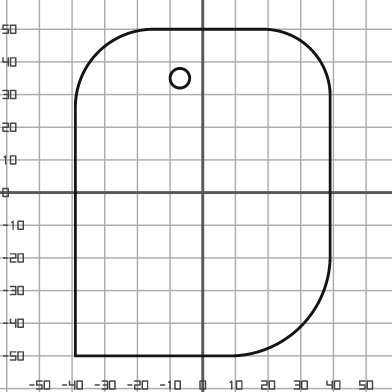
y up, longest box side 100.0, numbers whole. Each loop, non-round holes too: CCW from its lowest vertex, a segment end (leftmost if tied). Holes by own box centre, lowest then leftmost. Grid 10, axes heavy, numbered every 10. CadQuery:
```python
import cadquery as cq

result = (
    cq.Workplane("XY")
    .moveTo(-39.0, -50.0)
    .lineTo(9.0, -50.0)
    .threePointArc((30.0, -41.0), (39.0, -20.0))
    .lineTo(39.0, 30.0)
    .threePointArc((33.0, 44.0), (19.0, 50.0))
    .lineTo(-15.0, 50.0)
    .threePointArc((-32.0, 43.0), (-39.0, 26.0))
    .close()
    .moveTo(-7.0, 35.0)
    .circle(3.0)
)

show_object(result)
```